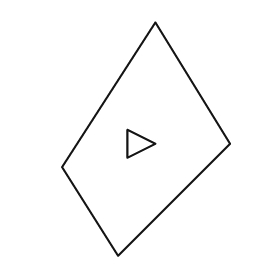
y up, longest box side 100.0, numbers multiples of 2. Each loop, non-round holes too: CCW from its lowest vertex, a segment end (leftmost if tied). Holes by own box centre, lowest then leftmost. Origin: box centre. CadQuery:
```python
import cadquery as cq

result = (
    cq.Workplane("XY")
    .moveTo(-12.0, -50.0)
    .lineTo(36.0, -2.0)
    .lineTo(4.0, 50.0)
    .lineTo(-36.0, -12.0)
    .close()
    .moveTo(-8.0, -8.0)
    .lineTo(4.0, -2.0)
    .lineTo(-8.0, 4.0)
    .close()
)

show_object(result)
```